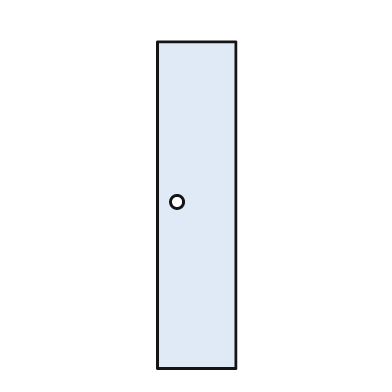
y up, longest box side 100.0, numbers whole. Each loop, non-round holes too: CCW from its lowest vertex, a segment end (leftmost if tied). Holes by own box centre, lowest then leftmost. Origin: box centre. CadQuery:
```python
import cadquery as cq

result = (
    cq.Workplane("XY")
    .moveTo(-12.0, -50.0)
    .lineTo(12.0, -50.0)
    .lineTo(12.0, 50.0)
    .lineTo(-12.0, 50.0)
    .close()
    .moveTo(-6.0, 1.0)
    .circle(2.0)
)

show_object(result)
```